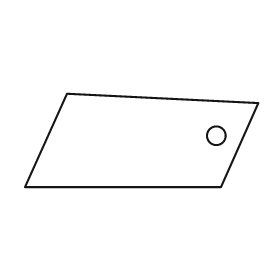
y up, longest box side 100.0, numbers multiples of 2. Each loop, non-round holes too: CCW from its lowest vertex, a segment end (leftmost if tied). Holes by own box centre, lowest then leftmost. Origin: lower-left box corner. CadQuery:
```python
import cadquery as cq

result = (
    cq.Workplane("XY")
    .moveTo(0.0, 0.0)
    .lineTo(84.0, 0.0)
    .lineTo(100.0, 36.0)
    .lineTo(18.0, 40.0)
    .close()
    .moveTo(82.0, 22.0)
    .circle(4.0)
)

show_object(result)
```